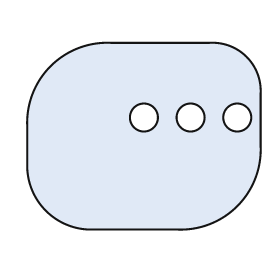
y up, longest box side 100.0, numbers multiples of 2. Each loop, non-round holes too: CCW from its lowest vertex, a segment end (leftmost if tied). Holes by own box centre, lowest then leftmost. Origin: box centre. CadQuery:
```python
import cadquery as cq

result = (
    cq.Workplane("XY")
    .moveTo(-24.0, -40.0)
    .lineTo(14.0, -40.0)
    .threePointArc((40.0, -30.0), (50.0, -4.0))
    .lineTo(50.0, 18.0)
    .threePointArc((44.0, 34.0), (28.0, 40.0))
    .lineTo(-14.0, 40.0)
    .threePointArc((-40.0, 30.0), (-50.0, 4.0))
    .lineTo(-50.0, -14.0)
    .threePointArc((-42.0, -32.0), (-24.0, -40.0))
    .close()
    .moveTo(0.0, 8.0)
    .circle(6.0)
    .moveTo(20.0, 8.0)
    .circle(6.0)
    .moveTo(40.0, 8.0)
    .circle(6.0)
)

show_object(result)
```